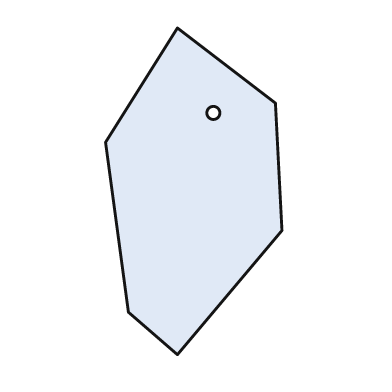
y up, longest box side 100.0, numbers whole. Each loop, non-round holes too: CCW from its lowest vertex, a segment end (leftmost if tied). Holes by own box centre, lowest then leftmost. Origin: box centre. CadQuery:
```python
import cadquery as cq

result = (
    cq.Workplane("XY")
    .moveTo(-5.0, -50.0)
    .lineTo(27.0, -12.0)
    .lineTo(25.0, 27.0)
    .lineTo(-5.0, 50.0)
    .lineTo(-27.0, 15.0)
    .lineTo(-20.0, -37.0)
    .close()
    .moveTo(6.0, 24.0)
    .circle(2.0)
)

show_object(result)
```